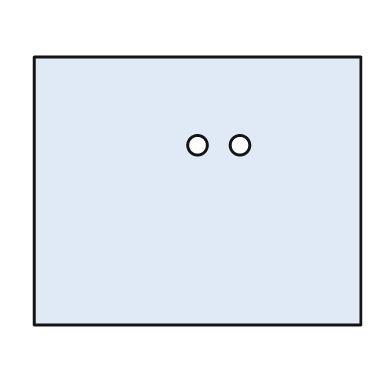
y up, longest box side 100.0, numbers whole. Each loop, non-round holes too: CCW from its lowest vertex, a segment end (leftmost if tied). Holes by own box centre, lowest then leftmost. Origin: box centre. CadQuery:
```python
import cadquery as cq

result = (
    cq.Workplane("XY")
    .moveTo(-50.0, -41.0)
    .lineTo(50.0, -41.0)
    .lineTo(50.0, 41.0)
    .lineTo(-50.0, 41.0)
    .close()
    .moveTo(0.0, 14.0)
    .circle(3.0)
    .moveTo(13.0, 14.0)
    .circle(3.0)
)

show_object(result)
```